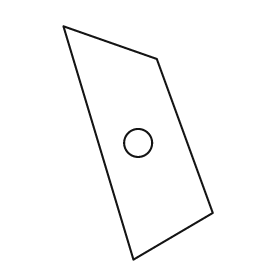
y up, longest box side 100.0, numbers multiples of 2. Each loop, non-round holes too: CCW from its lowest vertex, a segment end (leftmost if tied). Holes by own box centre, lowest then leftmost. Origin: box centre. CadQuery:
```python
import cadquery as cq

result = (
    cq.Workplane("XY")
    .moveTo(-2.0, -50.0)
    .lineTo(32.0, -30.0)
    .lineTo(8.0, 36.0)
    .lineTo(-32.0, 50.0)
    .close()
    .moveTo(0.0, 0.0)
    .circle(6.0)
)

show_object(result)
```